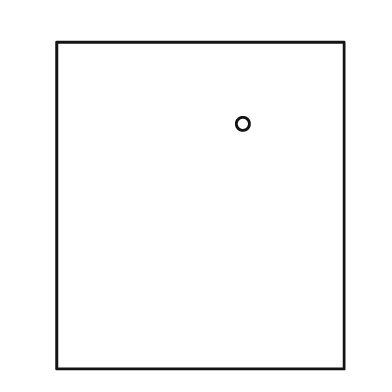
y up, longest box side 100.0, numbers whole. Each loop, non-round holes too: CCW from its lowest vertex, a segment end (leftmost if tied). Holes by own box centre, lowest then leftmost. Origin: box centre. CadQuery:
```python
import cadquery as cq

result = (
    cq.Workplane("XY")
    .moveTo(-44.0, -50.0)
    .lineTo(44.0, -50.0)
    .lineTo(44.0, 50.0)
    .lineTo(-44.0, 50.0)
    .close()
    .moveTo(13.0, 25.0)
    .circle(2.0)
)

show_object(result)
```